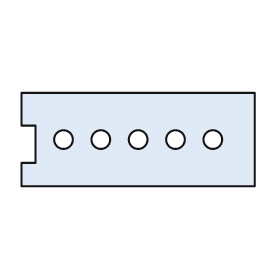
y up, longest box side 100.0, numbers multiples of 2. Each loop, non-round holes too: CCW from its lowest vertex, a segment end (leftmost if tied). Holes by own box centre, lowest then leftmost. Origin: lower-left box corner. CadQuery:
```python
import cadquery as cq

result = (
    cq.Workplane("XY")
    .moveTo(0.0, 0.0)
    .lineTo(100.0, 0.0)
    .lineTo(100.0, 40.0)
    .lineTo(0.0, 40.0)
    .lineTo(0.0, 26.0)
    .lineTo(6.0, 26.0)
    .lineTo(6.0, 10.0)
    .lineTo(0.0, 10.0)
    .close()
    .moveTo(18.0, 20.0)
    .circle(4.0)
    .moveTo(34.0, 20.0)
    .circle(4.0)
    .moveTo(50.0, 20.0)
    .circle(4.0)
    .moveTo(66.0, 20.0)
    .circle(4.0)
    .moveTo(82.0, 20.0)
    .circle(4.0)
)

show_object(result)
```